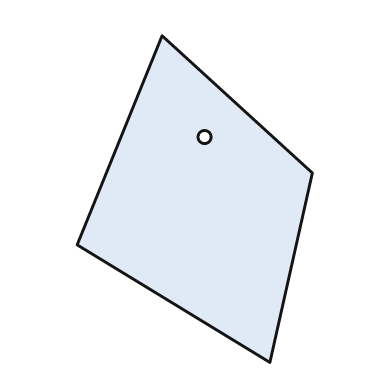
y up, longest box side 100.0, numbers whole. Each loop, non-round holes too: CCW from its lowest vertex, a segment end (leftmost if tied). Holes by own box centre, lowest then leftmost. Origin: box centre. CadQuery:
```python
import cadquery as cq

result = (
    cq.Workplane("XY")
    .moveTo(23.0, -50.0)
    .lineTo(36.0, 8.0)
    .lineTo(-10.0, 50.0)
    .lineTo(-36.0, -14.0)
    .close()
    .moveTo(3.0, 19.0)
    .circle(2.0)
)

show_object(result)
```